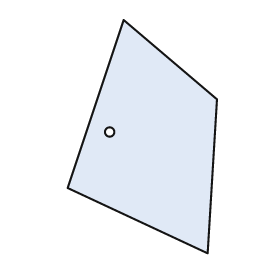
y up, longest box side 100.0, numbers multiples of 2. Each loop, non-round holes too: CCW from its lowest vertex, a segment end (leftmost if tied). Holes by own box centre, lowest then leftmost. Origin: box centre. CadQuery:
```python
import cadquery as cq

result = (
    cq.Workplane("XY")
    .moveTo(28.0, -50.0)
    .lineTo(32.0, 16.0)
    .lineTo(-8.0, 50.0)
    .lineTo(-32.0, -22.0)
    .close()
    .moveTo(-14.0, 2.0)
    .circle(2.0)
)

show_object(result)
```